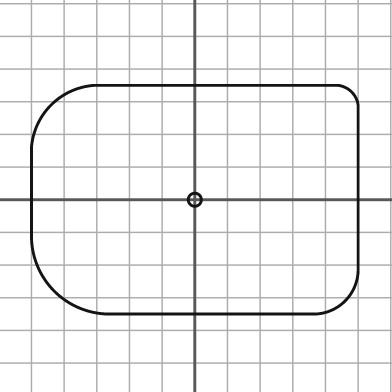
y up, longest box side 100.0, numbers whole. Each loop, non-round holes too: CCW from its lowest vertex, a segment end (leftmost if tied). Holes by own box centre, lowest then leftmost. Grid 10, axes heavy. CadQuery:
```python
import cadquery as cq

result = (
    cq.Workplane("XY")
    .moveTo(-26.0, -35.0)
    .lineTo(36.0, -35.0)
    .threePointArc((46.0, -31.0), (50.0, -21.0))
    .lineTo(50.0, 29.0)
    .threePointArc((48.0, 33.0), (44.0, 35.0))
    .lineTo(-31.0, 35.0)
    .threePointArc((-44.0, 29.0), (-50.0, 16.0))
    .lineTo(-50.0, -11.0)
    .threePointArc((-43.0, -28.0), (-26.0, -35.0))
    .close()
    .moveTo(0.0, 0.0)
    .circle(2.0)
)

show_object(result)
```